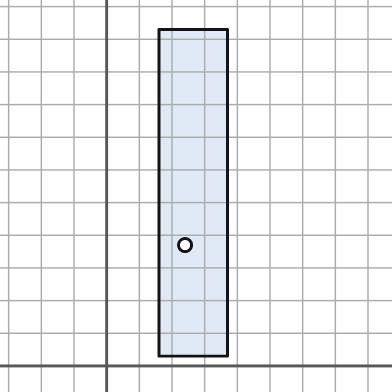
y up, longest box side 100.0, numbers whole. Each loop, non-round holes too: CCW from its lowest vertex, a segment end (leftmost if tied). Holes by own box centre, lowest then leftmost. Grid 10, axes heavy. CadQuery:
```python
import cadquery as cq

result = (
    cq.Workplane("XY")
    .moveTo(16.0, 3.0)
    .lineTo(37.0, 3.0)
    .lineTo(37.0, 103.0)
    .lineTo(16.0, 103.0)
    .close()
    .moveTo(24.0, 37.0)
    .circle(2.0)
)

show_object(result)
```